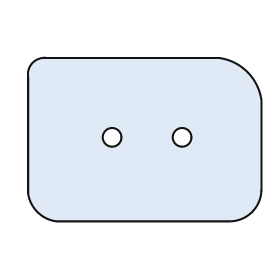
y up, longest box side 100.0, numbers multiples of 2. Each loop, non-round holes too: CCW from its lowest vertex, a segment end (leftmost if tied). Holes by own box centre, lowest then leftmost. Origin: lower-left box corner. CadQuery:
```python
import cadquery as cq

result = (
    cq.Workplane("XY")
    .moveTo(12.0, 0.0)
    .lineTo(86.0, 0.0)
    .threePointArc((96.0, 4.0), (100.0, 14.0))
    .lineTo(100.0, 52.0)
    .threePointArc((94.0, 64.0), (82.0, 70.0))
    .lineTo(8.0, 70.0)
    .threePointArc((2.0, 68.0), (0.0, 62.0))
    .lineTo(0.0, 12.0)
    .threePointArc((4.0, 4.0), (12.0, 0.0))
    .close()
    .moveTo(36.0, 36.0)
    .circle(4.0)
    .moveTo(66.0, 36.0)
    .circle(4.0)
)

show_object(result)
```